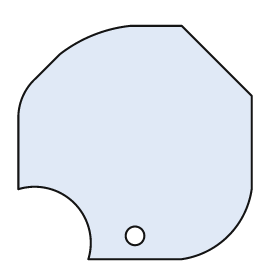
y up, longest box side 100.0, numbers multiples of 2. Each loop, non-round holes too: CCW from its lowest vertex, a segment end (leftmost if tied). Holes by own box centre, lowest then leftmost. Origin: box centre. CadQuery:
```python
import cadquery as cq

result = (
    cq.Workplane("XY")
    .moveTo(-20.0, -50.0)
    .lineTo(20.0, -50.0)
    .threePointArc((40.0, -40.0), (50.0, -20.0))
    .lineTo(50.0, 20.0)
    .lineTo(20.0, 50.0)
    .lineTo(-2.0, 50.0)
    .threePointArc((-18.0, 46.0), (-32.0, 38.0))
    .lineTo(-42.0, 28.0)
    .threePointArc((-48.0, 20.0), (-50.0, 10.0))
    .lineTo(-50.0, -20.0)
    .threePointArc((-26.0, -26.0), (-20.0, -50.0))
    .close()
    .moveTo(0.0, -40.0)
    .circle(4.0)
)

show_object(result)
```